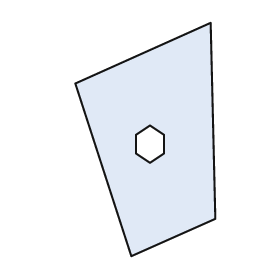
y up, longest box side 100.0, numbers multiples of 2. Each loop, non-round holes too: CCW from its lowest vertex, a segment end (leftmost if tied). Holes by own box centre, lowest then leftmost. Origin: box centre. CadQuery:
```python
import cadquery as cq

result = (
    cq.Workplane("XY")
    .moveTo(-6.0, -50.0)
    .lineTo(30.0, -34.0)
    .lineTo(28.0, 50.0)
    .lineTo(-30.0, 24.0)
    .close()
    .moveTo(2.0, -10.0)
    .lineTo(8.0, -6.0)
    .lineTo(8.0, 2.0)
    .lineTo(2.0, 6.0)
    .lineTo(-4.0, 2.0)
    .lineTo(-4.0, -6.0)
    .close()
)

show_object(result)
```